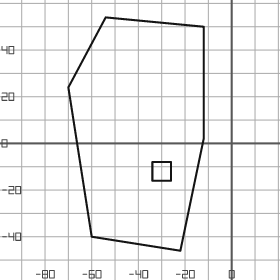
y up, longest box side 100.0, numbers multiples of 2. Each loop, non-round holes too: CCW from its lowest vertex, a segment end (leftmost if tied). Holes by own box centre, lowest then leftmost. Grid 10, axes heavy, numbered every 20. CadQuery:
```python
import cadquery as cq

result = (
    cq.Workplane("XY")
    .moveTo(-22.0, -46.0)
    .lineTo(-12.0, 2.0)
    .lineTo(-12.0, 50.0)
    .lineTo(-54.0, 54.0)
    .lineTo(-70.0, 24.0)
    .lineTo(-60.0, -40.0)
    .close()
    .moveTo(-34.0, -16.0)
    .lineTo(-26.0, -16.0)
    .lineTo(-26.0, -8.0)
    .lineTo(-34.0, -8.0)
    .close()
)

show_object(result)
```